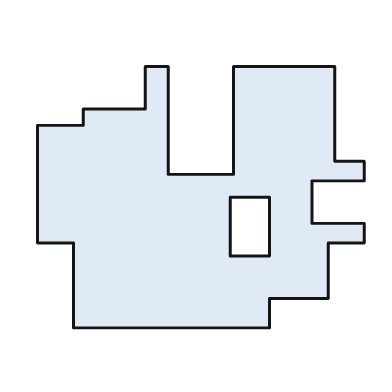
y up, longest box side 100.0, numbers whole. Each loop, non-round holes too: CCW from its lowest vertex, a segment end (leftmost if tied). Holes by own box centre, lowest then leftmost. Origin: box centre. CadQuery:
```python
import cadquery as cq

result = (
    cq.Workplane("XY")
    .moveTo(-39.0, -40.0)
    .lineTo(21.0, -40.0)
    .lineTo(21.0, -31.0)
    .lineTo(39.0, -31.0)
    .lineTo(39.0, -14.0)
    .lineTo(50.0, -14.0)
    .lineTo(50.0, -8.0)
    .lineTo(34.0, -8.0)
    .lineTo(34.0, 5.0)
    .lineTo(50.0, 5.0)
    .lineTo(50.0, 11.0)
    .lineTo(41.0, 11.0)
    .lineTo(41.0, 40.0)
    .lineTo(10.0, 40.0)
    .lineTo(10.0, 7.0)
    .lineTo(-10.0, 7.0)
    .lineTo(-10.0, 40.0)
    .lineTo(-17.0, 40.0)
    .lineTo(-17.0, 27.0)
    .lineTo(-36.0, 27.0)
    .lineTo(-36.0, 22.0)
    .lineTo(-50.0, 22.0)
    .lineTo(-50.0, -14.0)
    .lineTo(-39.0, -14.0)
    .close()
    .moveTo(9.0, -18.0)
    .lineTo(21.0, -18.0)
    .lineTo(21.0, 0.0)
    .lineTo(9.0, 0.0)
    .close()
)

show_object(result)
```